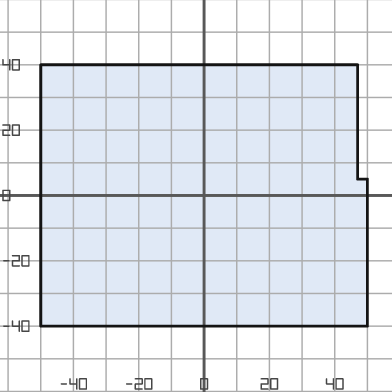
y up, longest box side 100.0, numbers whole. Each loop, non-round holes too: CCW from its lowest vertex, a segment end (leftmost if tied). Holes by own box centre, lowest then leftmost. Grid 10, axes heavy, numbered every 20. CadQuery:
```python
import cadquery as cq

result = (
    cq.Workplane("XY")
    .moveTo(-50.0, -40.0)
    .lineTo(50.0, -40.0)
    .lineTo(50.0, 5.0)
    .lineTo(47.0, 5.0)
    .lineTo(47.0, 40.0)
    .lineTo(-50.0, 40.0)
    .close()
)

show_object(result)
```